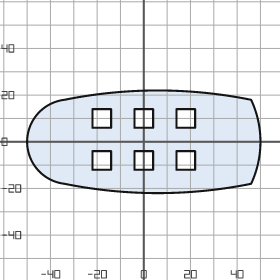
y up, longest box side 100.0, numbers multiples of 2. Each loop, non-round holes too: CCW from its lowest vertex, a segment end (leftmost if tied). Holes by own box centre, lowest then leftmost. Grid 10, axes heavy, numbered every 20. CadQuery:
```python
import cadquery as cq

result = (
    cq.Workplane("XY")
    .moveTo(-34.0, -18.0)
    .threePointArc((6.0, -22.0), (46.0, -18.0))
    .threePointArc((50.0, 0.0), (46.0, 18.0))
    .threePointArc((6.0, 22.0), (-34.0, 18.0))
    .threePointArc((-50.0, 0.0), (-34.0, -18.0))
    .close()
    .moveTo(-22.0, -12.0)
    .lineTo(-14.0, -12.0)
    .lineTo(-14.0, -4.0)
    .lineTo(-22.0, -4.0)
    .close()
    .moveTo(-4.0, -12.0)
    .lineTo(4.0, -12.0)
    .lineTo(4.0, -4.0)
    .lineTo(-4.0, -4.0)
    .close()
    .moveTo(14.0, -12.0)
    .lineTo(22.0, -12.0)
    .lineTo(22.0, -4.0)
    .lineTo(14.0, -4.0)
    .close()
    .moveTo(-22.0, 6.0)
    .lineTo(-14.0, 6.0)
    .lineTo(-14.0, 14.0)
    .lineTo(-22.0, 14.0)
    .close()
    .moveTo(-4.0, 6.0)
    .lineTo(4.0, 6.0)
    .lineTo(4.0, 14.0)
    .lineTo(-4.0, 14.0)
    .close()
    .moveTo(14.0, 6.0)
    .lineTo(22.0, 6.0)
    .lineTo(22.0, 14.0)
    .lineTo(14.0, 14.0)
    .close()
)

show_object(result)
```